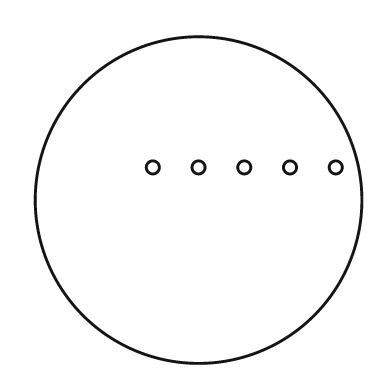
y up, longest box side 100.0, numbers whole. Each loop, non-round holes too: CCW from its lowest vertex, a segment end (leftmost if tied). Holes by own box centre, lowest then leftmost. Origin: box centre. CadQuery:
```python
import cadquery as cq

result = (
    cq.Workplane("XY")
    .moveTo(0.0, 0.0)
    .circle(50.0)
    .moveTo(-14.0, 10.0)
    .circle(2.0)
    .moveTo(0.0, 10.0)
    .circle(2.0)
    .moveTo(14.0, 10.0)
    .circle(2.0)
    .moveTo(28.0, 10.0)
    .circle(2.0)
    .moveTo(42.0, 10.0)
    .circle(2.0)
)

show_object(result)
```